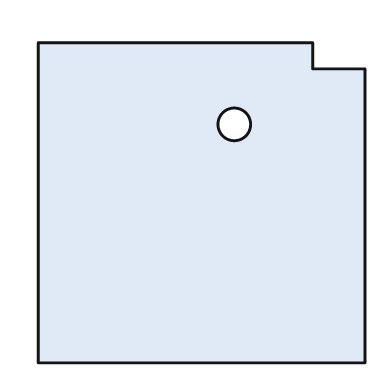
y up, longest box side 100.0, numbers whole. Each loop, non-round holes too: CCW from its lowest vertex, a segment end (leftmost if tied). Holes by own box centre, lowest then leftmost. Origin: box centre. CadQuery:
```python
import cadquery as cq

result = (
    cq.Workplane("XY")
    .moveTo(-50.0, -49.0)
    .lineTo(50.0, -49.0)
    .lineTo(50.0, 41.0)
    .lineTo(34.0, 41.0)
    .lineTo(34.0, 49.0)
    .lineTo(-50.0, 49.0)
    .close()
    .moveTo(10.0, 24.0)
    .circle(5.0)
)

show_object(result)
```